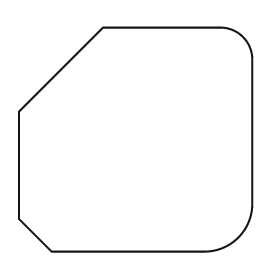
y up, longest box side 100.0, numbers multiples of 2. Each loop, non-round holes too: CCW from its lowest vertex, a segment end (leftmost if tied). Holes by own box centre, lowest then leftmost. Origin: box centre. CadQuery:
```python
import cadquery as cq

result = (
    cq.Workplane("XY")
    .moveTo(-36.0, -48.0)
    .lineTo(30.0, -48.0)
    .threePointArc((44.0, -42.0), (50.0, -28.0))
    .lineTo(50.0, 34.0)
    .threePointArc((46.0, 44.0), (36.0, 48.0))
    .lineTo(-14.0, 48.0)
    .lineTo(-50.0, 12.0)
    .lineTo(-50.0, -34.0)
    .close()
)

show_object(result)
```